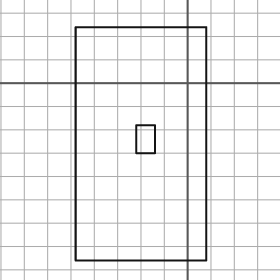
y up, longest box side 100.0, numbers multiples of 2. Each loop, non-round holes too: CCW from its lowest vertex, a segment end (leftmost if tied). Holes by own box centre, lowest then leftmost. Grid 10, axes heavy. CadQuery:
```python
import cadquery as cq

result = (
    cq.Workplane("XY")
    .moveTo(-48.0, -76.0)
    .lineTo(8.0, -76.0)
    .lineTo(8.0, 24.0)
    .lineTo(-48.0, 24.0)
    .close()
    .moveTo(-22.0, -30.0)
    .lineTo(-14.0, -30.0)
    .lineTo(-14.0, -18.0)
    .lineTo(-22.0, -18.0)
    .close()
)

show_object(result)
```